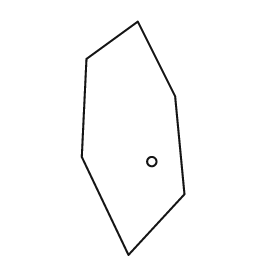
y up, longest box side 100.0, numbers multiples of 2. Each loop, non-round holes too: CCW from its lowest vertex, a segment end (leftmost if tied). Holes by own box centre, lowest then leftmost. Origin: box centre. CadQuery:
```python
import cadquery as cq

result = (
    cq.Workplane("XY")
    .moveTo(-2.0, -50.0)
    .lineTo(22.0, -24.0)
    .lineTo(18.0, 18.0)
    .lineTo(2.0, 50.0)
    .lineTo(-20.0, 34.0)
    .lineTo(-22.0, -8.0)
    .close()
    .moveTo(8.0, -10.0)
    .circle(2.0)
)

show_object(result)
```